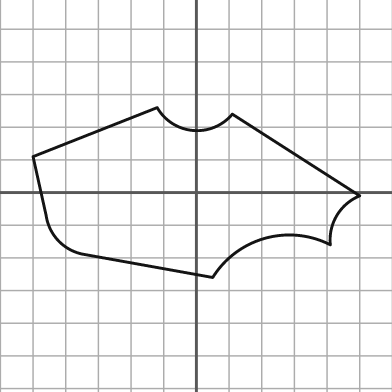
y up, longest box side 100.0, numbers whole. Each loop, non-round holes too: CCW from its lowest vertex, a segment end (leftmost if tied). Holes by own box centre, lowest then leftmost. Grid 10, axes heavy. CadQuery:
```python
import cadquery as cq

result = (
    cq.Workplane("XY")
    .moveTo(5.0, -26.0)
    .threePointArc((21.0, -14.0), (41.0, -16.0))
    .threePointArc((43.0, -7.0), (50.0, -1.0))
    .lineTo(11.0, 24.0)
    .threePointArc((-1.0, 19.0), (-12.0, 26.0))
    .lineTo(-50.0, 11.0)
    .lineTo(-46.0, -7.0)
    .threePointArc((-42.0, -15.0), (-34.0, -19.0))
    .close()
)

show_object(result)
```